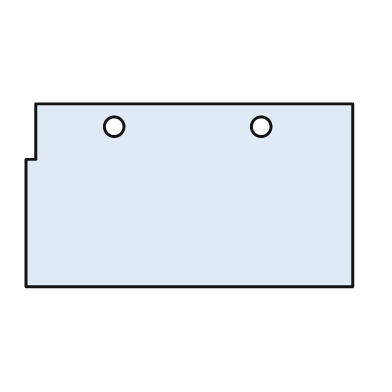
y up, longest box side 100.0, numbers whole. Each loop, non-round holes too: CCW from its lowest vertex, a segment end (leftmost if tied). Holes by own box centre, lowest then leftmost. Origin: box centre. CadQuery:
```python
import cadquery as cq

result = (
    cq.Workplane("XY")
    .moveTo(-50.0, -28.0)
    .lineTo(50.0, -28.0)
    .lineTo(50.0, 28.0)
    .lineTo(-47.0, 28.0)
    .lineTo(-47.0, 11.0)
    .lineTo(-50.0, 11.0)
    .close()
    .moveTo(-23.0, 21.0)
    .circle(3.0)
    .moveTo(22.0, 21.0)
    .circle(3.0)
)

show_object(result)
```